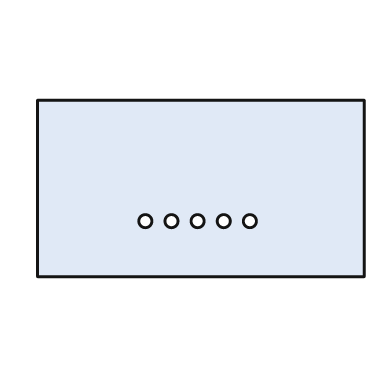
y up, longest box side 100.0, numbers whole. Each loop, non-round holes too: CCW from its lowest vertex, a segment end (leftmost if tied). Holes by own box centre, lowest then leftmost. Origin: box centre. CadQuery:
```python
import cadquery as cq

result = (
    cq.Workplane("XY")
    .moveTo(-50.0, -27.0)
    .lineTo(50.0, -27.0)
    .lineTo(50.0, 27.0)
    .lineTo(-50.0, 27.0)
    .close()
    .moveTo(-17.0, -10.0)
    .circle(2.0)
    .moveTo(-9.0, -10.0)
    .circle(2.0)
    .moveTo(-1.0, -10.0)
    .circle(2.0)
    .moveTo(7.0, -10.0)
    .circle(2.0)
    .moveTo(15.0, -10.0)
    .circle(2.0)
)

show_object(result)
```